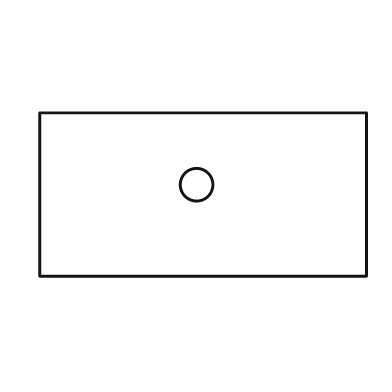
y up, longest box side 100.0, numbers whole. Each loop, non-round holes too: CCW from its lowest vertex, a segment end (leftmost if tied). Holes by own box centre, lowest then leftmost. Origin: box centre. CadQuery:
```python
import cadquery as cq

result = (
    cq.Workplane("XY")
    .moveTo(-50.0, -25.0)
    .lineTo(50.0, -25.0)
    .lineTo(50.0, 25.0)
    .lineTo(-50.0, 25.0)
    .close()
    .moveTo(-2.0, 3.0)
    .circle(5.0)
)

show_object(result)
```